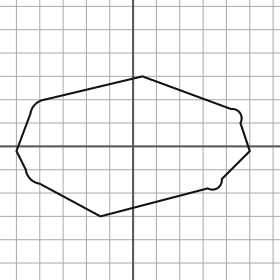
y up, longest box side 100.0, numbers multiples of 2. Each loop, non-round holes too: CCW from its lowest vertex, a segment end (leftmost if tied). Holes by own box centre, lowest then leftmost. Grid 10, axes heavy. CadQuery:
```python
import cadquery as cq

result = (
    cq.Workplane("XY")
    .moveTo(-14.0, -30.0)
    .lineTo(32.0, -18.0)
    .threePointArc((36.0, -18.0), (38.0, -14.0))
    .lineTo(50.0, -2.0)
    .lineTo(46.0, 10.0)
    .threePointArc((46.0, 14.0), (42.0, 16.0))
    .lineTo(4.0, 30.0)
    .lineTo(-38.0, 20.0)
    .threePointArc((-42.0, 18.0), (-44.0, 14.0))
    .lineTo(-50.0, -2.0)
    .lineTo(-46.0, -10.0)
    .threePointArc((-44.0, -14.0), (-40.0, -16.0))
    .close()
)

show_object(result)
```